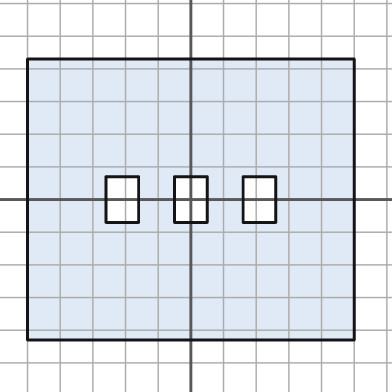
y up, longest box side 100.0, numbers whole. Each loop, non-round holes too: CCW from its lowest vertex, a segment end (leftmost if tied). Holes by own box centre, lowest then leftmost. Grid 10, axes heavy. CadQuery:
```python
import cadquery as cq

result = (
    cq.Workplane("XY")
    .moveTo(-50.0, -43.0)
    .lineTo(50.0, -43.0)
    .lineTo(50.0, 43.0)
    .lineTo(-50.0, 43.0)
    .close()
    .moveTo(-26.0, -7.0)
    .lineTo(-16.0, -7.0)
    .lineTo(-16.0, 7.0)
    .lineTo(-26.0, 7.0)
    .close()
    .moveTo(-5.0, -7.0)
    .lineTo(5.0, -7.0)
    .lineTo(5.0, 7.0)
    .lineTo(-5.0, 7.0)
    .close()
    .moveTo(16.0, -7.0)
    .lineTo(26.0, -7.0)
    .lineTo(26.0, 7.0)
    .lineTo(16.0, 7.0)
    .close()
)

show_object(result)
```